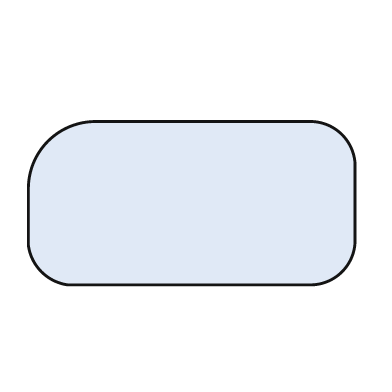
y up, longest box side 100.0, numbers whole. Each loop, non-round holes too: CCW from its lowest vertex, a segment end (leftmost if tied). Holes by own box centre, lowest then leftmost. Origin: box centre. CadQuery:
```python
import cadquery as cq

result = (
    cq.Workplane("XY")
    .moveTo(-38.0, -25.0)
    .lineTo(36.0, -25.0)
    .threePointArc((46.0, -21.0), (50.0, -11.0))
    .lineTo(50.0, 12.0)
    .threePointArc((46.0, 21.0), (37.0, 25.0))
    .lineTo(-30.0, 25.0)
    .threePointArc((-44.0, 19.0), (-50.0, 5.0))
    .lineTo(-50.0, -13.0)
    .threePointArc((-46.0, -21.0), (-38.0, -25.0))
    .close()
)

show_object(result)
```